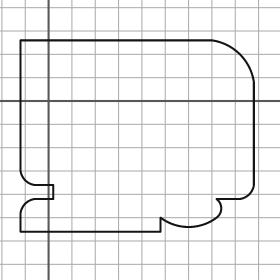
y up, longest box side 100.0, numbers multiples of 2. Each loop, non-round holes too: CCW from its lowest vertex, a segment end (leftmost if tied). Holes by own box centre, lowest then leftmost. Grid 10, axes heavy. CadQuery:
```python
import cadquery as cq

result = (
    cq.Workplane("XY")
    .moveTo(-12.0, -56.0)
    .lineTo(48.0, -56.0)
    .lineTo(48.0, -50.0)
    .threePointArc((60.0, -54.0), (72.0, -50.0))
    .threePointArc((74.0, -46.0), (72.0, -42.0))
    .lineTo(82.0, -42.0)
    .threePointArc((86.0, -40.0), (88.0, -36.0))
    .lineTo(88.0, 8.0)
    .threePointArc((82.0, 20.0), (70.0, 26.0))
    .lineTo(-12.0, 26.0)
    .lineTo(-12.0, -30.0)
    .threePointArc((-10.0, -34.0), (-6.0, -36.0))
    .lineTo(2.0, -36.0)
    .lineTo(2.0, -42.0)
    .lineTo(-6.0, -42.0)
    .threePointArc((-10.0, -44.0), (-12.0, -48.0))
    .close()
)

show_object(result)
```